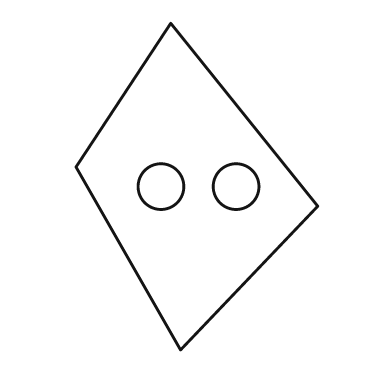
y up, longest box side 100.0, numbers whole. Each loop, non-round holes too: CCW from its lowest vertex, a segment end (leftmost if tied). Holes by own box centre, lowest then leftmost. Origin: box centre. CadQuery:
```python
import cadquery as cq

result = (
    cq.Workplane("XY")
    .moveTo(-5.0, -50.0)
    .lineTo(37.0, -6.0)
    .lineTo(-8.0, 50.0)
    .lineTo(-37.0, 6.0)
    .close()
    .moveTo(-11.0, 0.0)
    .circle(7.0)
    .moveTo(12.0, 0.0)
    .circle(7.0)
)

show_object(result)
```